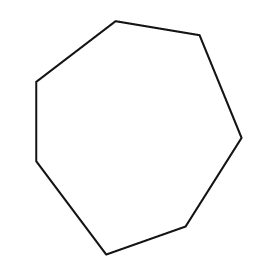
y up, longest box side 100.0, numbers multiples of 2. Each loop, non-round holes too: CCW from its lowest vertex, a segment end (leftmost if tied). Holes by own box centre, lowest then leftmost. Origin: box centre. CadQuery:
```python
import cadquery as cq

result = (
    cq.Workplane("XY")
    .moveTo(-14.0, -50.0)
    .lineTo(20.0, -38.0)
    .lineTo(44.0, 0.0)
    .lineTo(26.0, 44.0)
    .lineTo(-10.0, 50.0)
    .lineTo(-44.0, 24.0)
    .lineTo(-44.0, -10.0)
    .close()
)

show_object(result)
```